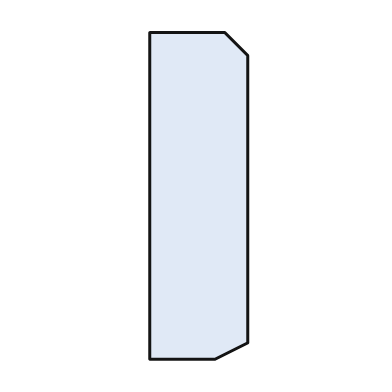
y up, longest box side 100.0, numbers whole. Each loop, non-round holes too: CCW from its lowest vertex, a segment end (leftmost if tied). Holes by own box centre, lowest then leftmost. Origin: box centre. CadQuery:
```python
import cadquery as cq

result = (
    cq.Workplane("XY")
    .moveTo(-15.0, -50.0)
    .lineTo(5.0, -50.0)
    .lineTo(15.0, -45.0)
    .lineTo(15.0, 43.0)
    .lineTo(8.0, 50.0)
    .lineTo(-15.0, 50.0)
    .close()
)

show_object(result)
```